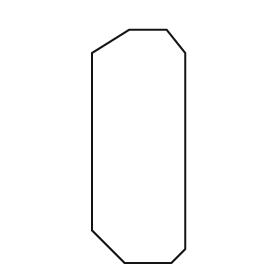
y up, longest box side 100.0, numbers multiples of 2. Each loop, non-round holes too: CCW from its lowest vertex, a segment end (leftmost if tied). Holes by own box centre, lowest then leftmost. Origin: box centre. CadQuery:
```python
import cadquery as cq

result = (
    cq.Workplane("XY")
    .moveTo(-6.0, -50.0)
    .lineTo(14.0, -50.0)
    .lineTo(20.0, -44.0)
    .lineTo(20.0, 40.0)
    .lineTo(12.0, 50.0)
    .lineTo(-4.0, 50.0)
    .lineTo(-20.0, 40.0)
    .lineTo(-20.0, -36.0)
    .close()
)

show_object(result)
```